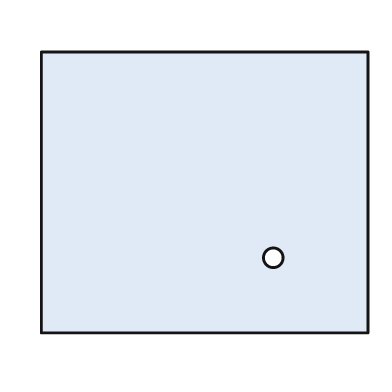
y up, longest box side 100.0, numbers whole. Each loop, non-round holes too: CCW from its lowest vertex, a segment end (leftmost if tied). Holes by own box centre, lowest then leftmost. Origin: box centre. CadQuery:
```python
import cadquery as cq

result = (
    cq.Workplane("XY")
    .moveTo(-50.0, -43.0)
    .lineTo(50.0, -43.0)
    .lineTo(50.0, 43.0)
    .lineTo(-50.0, 43.0)
    .close()
    .moveTo(21.0, -20.0)
    .circle(3.0)
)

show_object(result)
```